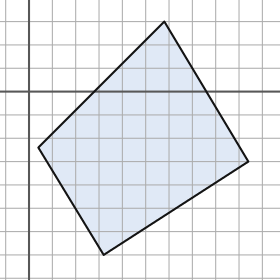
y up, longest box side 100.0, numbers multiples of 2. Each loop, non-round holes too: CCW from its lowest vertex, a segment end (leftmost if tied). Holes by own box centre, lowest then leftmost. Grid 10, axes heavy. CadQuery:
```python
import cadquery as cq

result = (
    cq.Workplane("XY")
    .moveTo(32.0, -70.0)
    .lineTo(94.0, -30.0)
    .lineTo(58.0, 30.0)
    .lineTo(4.0, -24.0)
    .close()
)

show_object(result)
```